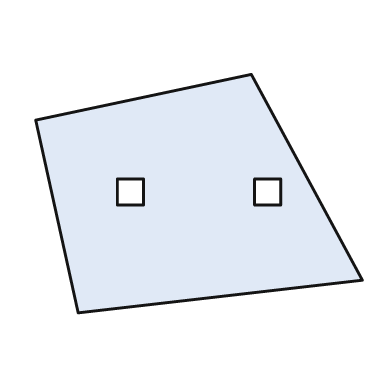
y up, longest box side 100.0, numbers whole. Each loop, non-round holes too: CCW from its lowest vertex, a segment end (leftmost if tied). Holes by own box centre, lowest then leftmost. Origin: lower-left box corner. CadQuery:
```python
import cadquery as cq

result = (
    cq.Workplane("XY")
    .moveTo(13.0, 0.0)
    .lineTo(100.0, 10.0)
    .lineTo(66.0, 73.0)
    .lineTo(0.0, 59.0)
    .close()
    .moveTo(25.0, 33.0)
    .lineTo(33.0, 33.0)
    .lineTo(33.0, 41.0)
    .lineTo(25.0, 41.0)
    .close()
    .moveTo(67.0, 33.0)
    .lineTo(75.0, 33.0)
    .lineTo(75.0, 41.0)
    .lineTo(67.0, 41.0)
    .close()
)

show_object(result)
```